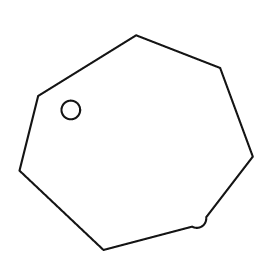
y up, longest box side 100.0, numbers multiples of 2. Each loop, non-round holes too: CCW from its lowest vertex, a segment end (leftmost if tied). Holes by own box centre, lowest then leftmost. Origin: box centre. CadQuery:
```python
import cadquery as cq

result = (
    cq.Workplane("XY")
    .moveTo(-14.0, -46.0)
    .lineTo(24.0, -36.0)
    .threePointArc((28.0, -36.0), (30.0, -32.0))
    .lineTo(50.0, -6.0)
    .lineTo(36.0, 32.0)
    .lineTo(0.0, 46.0)
    .lineTo(-42.0, 20.0)
    .lineTo(-50.0, -12.0)
    .close()
    .moveTo(-28.0, 14.0)
    .circle(4.0)
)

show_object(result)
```